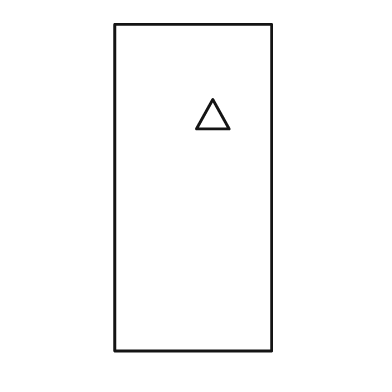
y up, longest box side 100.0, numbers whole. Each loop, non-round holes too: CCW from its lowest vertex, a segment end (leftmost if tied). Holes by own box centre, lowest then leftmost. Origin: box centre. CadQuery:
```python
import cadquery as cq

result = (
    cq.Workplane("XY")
    .moveTo(-24.0, -50.0)
    .lineTo(24.0, -50.0)
    .lineTo(24.0, 50.0)
    .lineTo(-24.0, 50.0)
    .close()
    .moveTo(1.0, 18.0)
    .lineTo(11.0, 18.0)
    .lineTo(6.0, 27.0)
    .close()
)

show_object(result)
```